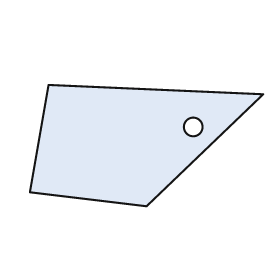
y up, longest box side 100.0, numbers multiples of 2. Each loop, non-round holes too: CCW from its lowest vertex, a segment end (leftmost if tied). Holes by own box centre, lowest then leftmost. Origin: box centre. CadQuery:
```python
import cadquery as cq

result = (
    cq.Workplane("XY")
    .moveTo(0.0, -26.0)
    .lineTo(50.0, 22.0)
    .lineTo(-42.0, 26.0)
    .lineTo(-50.0, -20.0)
    .close()
    .moveTo(20.0, 8.0)
    .circle(4.0)
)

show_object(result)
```